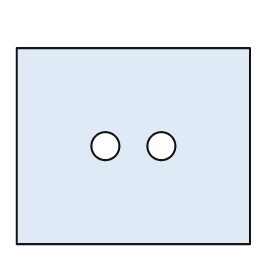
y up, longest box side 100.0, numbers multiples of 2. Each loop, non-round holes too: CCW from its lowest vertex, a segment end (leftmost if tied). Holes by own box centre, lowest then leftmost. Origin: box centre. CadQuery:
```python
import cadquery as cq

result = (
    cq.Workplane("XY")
    .moveTo(-50.0, -42.0)
    .lineTo(50.0, -42.0)
    .lineTo(50.0, 42.0)
    .lineTo(-50.0, 42.0)
    .close()
    .moveTo(-12.0, 0.0)
    .circle(6.0)
    .moveTo(12.0, 0.0)
    .circle(6.0)
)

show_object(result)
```